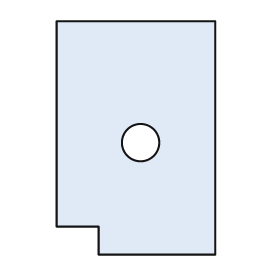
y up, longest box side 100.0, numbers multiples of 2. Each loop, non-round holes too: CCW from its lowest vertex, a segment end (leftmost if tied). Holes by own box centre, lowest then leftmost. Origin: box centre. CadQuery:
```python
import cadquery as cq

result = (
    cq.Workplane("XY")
    .moveTo(-16.0, -50.0)
    .lineTo(34.0, -50.0)
    .lineTo(34.0, 50.0)
    .lineTo(-34.0, 50.0)
    .lineTo(-34.0, -38.0)
    .lineTo(-16.0, -38.0)
    .close()
    .moveTo(2.0, -2.0)
    .circle(8.0)
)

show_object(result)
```